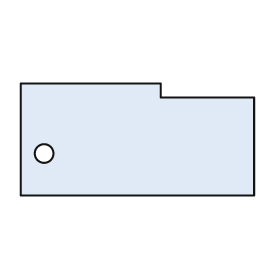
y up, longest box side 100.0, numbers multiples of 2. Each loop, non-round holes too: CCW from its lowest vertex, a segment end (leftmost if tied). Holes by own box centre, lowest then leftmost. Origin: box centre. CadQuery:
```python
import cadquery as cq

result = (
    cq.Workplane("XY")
    .moveTo(-50.0, -24.0)
    .lineTo(50.0, -24.0)
    .lineTo(50.0, 18.0)
    .lineTo(10.0, 18.0)
    .lineTo(10.0, 24.0)
    .lineTo(-50.0, 24.0)
    .close()
    .moveTo(-40.0, -6.0)
    .circle(4.0)
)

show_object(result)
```